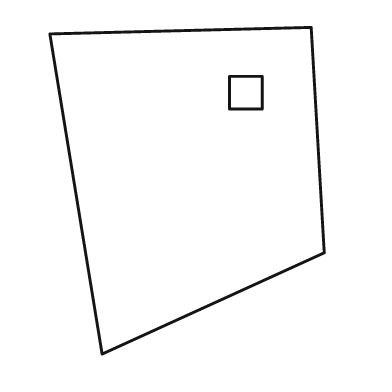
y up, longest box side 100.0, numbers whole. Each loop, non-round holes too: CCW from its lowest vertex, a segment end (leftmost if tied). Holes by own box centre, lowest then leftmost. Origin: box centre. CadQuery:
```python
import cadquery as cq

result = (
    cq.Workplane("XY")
    .moveTo(-26.0, -50.0)
    .lineTo(42.0, -19.0)
    .lineTo(38.0, 50.0)
    .lineTo(-42.0, 48.0)
    .close()
    .moveTo(13.0, 25.0)
    .lineTo(23.0, 25.0)
    .lineTo(23.0, 35.0)
    .lineTo(13.0, 35.0)
    .close()
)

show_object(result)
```